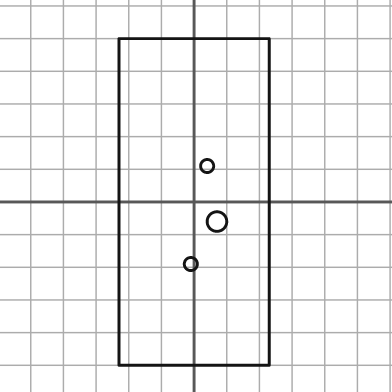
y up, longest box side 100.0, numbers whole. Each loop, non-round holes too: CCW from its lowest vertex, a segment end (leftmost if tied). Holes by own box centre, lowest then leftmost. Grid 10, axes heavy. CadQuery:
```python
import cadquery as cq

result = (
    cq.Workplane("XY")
    .moveTo(-23.0, -50.0)
    .lineTo(23.0, -50.0)
    .lineTo(23.0, 50.0)
    .lineTo(-23.0, 50.0)
    .close()
    .moveTo(-1.0, -19.0)
    .circle(2.0)
    .moveTo(7.0, -6.0)
    .circle(3.0)
    .moveTo(4.0, 11.0)
    .circle(2.0)
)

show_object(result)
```